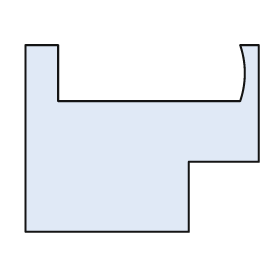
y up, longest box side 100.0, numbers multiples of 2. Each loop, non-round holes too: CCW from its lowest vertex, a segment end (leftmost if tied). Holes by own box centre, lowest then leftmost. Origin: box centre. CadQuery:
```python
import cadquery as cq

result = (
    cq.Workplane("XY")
    .moveTo(-50.0, -40.0)
    .lineTo(20.0, -40.0)
    .lineTo(20.0, -10.0)
    .lineTo(50.0, -10.0)
    .lineTo(50.0, 40.0)
    .lineTo(42.0, 40.0)
    .threePointArc((44.0, 28.0), (42.0, 16.0))
    .lineTo(-36.0, 16.0)
    .lineTo(-36.0, 40.0)
    .lineTo(-50.0, 40.0)
    .close()
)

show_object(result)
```